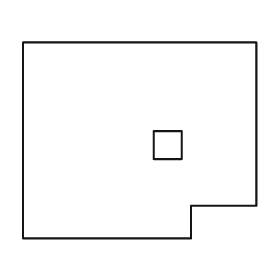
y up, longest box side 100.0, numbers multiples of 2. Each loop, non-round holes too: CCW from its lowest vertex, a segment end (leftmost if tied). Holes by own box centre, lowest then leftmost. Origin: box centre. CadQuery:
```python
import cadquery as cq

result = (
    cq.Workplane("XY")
    .moveTo(-50.0, -42.0)
    .lineTo(22.0, -42.0)
    .lineTo(22.0, -28.0)
    .lineTo(50.0, -28.0)
    .lineTo(50.0, 42.0)
    .lineTo(-50.0, 42.0)
    .close()
    .moveTo(6.0, -8.0)
    .lineTo(18.0, -8.0)
    .lineTo(18.0, 4.0)
    .lineTo(6.0, 4.0)
    .close()
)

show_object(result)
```